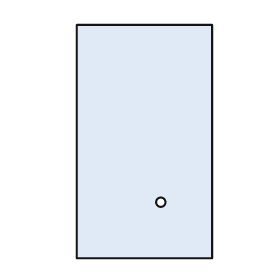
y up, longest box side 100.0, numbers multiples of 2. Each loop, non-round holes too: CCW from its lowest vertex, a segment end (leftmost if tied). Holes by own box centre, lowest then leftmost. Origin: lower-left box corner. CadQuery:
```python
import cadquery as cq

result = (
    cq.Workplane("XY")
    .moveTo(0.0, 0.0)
    .lineTo(58.0, 0.0)
    .lineTo(58.0, 100.0)
    .lineTo(0.0, 100.0)
    .close()
    .moveTo(36.0, 24.0)
    .circle(2.0)
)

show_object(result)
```